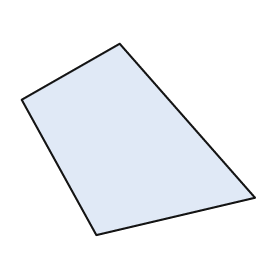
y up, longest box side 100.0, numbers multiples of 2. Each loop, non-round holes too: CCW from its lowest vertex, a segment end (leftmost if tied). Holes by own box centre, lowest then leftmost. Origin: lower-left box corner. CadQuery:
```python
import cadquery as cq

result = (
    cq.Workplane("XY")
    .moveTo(32.0, 0.0)
    .lineTo(100.0, 16.0)
    .lineTo(42.0, 82.0)
    .lineTo(0.0, 58.0)
    .close()
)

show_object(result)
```